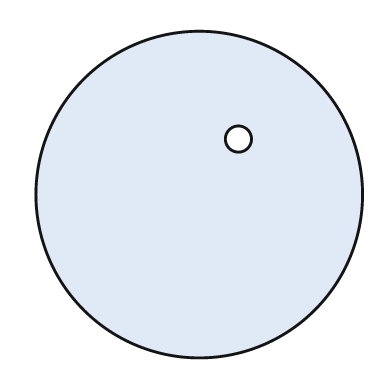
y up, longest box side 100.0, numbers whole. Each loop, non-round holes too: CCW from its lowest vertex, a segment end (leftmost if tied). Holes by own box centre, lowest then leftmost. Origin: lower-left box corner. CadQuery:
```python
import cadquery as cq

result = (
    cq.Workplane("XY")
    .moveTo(50.0, 50.0)
    .circle(50.0)
    .moveTo(62.0, 67.0)
    .circle(4.0)
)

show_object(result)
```